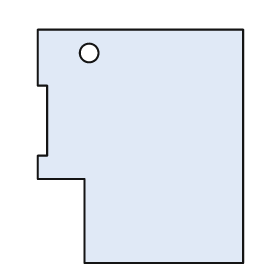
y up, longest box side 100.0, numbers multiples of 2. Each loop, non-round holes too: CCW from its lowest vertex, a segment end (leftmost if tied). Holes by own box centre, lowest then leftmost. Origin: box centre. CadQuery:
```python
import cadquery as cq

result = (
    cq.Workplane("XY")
    .moveTo(-24.0, -50.0)
    .lineTo(44.0, -50.0)
    .lineTo(44.0, 50.0)
    .lineTo(-44.0, 50.0)
    .lineTo(-44.0, 26.0)
    .lineTo(-40.0, 26.0)
    .lineTo(-40.0, -4.0)
    .lineTo(-44.0, -4.0)
    .lineTo(-44.0, -14.0)
    .lineTo(-24.0, -14.0)
    .close()
    .moveTo(-22.0, 40.0)
    .circle(4.0)
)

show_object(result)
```